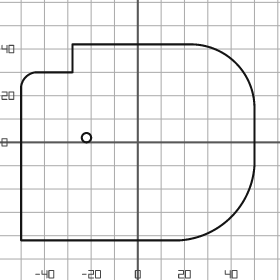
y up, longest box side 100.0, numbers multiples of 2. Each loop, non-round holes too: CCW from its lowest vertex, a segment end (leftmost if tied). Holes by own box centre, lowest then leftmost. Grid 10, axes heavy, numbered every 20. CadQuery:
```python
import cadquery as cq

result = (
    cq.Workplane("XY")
    .moveTo(-50.0, -42.0)
    .lineTo(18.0, -42.0)
    .threePointArc((40.0, -32.0), (50.0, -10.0))
    .lineTo(50.0, 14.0)
    .threePointArc((42.0, 34.0), (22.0, 42.0))
    .lineTo(-28.0, 42.0)
    .lineTo(-28.0, 30.0)
    .lineTo(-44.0, 30.0)
    .threePointArc((-48.0, 28.0), (-50.0, 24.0))
    .close()
    .moveTo(-22.0, 2.0)
    .circle(2.0)
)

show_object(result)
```